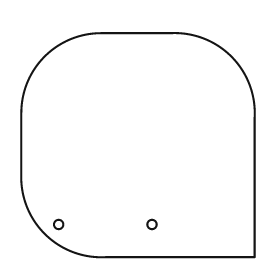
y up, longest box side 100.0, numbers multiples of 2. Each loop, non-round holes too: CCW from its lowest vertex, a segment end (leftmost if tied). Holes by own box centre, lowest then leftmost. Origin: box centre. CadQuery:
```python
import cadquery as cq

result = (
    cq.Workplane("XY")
    .moveTo(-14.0, -48.0)
    .lineTo(50.0, -48.0)
    .lineTo(50.0, 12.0)
    .threePointArc((40.0, 38.0), (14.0, 48.0))
    .lineTo(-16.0, 48.0)
    .threePointArc((-40.0, 38.0), (-50.0, 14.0))
    .lineTo(-50.0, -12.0)
    .threePointArc((-40.0, -38.0), (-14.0, -48.0))
    .close()
    .moveTo(-34.0, -34.0)
    .circle(2.0)
    .moveTo(6.0, -34.0)
    .circle(2.0)
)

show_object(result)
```